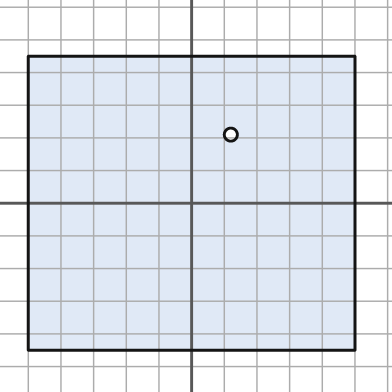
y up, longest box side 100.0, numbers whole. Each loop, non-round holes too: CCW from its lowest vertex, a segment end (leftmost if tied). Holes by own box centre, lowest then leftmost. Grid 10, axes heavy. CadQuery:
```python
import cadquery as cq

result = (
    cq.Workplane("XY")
    .moveTo(-50.0, -45.0)
    .lineTo(50.0, -45.0)
    .lineTo(50.0, 45.0)
    .lineTo(-50.0, 45.0)
    .close()
    .moveTo(12.0, 21.0)
    .circle(2.0)
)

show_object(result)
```